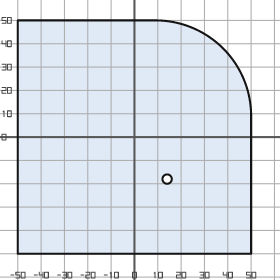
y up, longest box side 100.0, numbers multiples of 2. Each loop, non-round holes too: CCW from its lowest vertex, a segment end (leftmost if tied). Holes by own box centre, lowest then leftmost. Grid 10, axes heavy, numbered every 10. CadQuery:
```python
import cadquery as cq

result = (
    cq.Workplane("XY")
    .moveTo(-50.0, -50.0)
    .lineTo(50.0, -50.0)
    .lineTo(50.0, 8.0)
    .threePointArc((38.0, 38.0), (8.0, 50.0))
    .lineTo(-50.0, 50.0)
    .close()
    .moveTo(14.0, -18.0)
    .circle(2.0)
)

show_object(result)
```